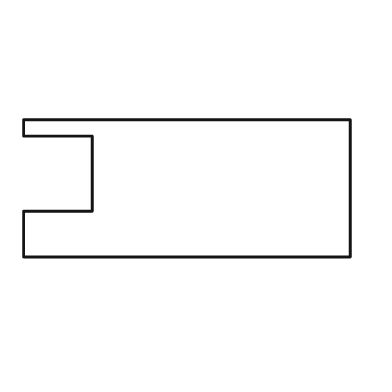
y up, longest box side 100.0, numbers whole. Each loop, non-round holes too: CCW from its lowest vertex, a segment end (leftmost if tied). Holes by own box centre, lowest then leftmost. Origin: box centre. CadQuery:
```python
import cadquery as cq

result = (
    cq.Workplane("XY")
    .moveTo(-50.0, -21.0)
    .lineTo(50.0, -21.0)
    .lineTo(50.0, 21.0)
    .lineTo(-50.0, 21.0)
    .lineTo(-50.0, 16.0)
    .lineTo(-29.0, 16.0)
    .lineTo(-29.0, -7.0)
    .lineTo(-50.0, -7.0)
    .close()
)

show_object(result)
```